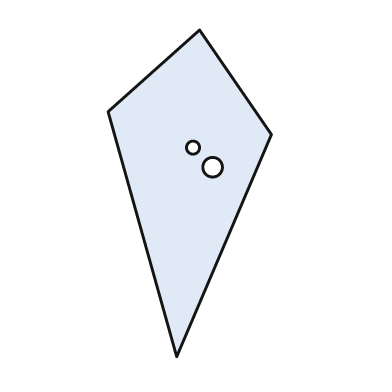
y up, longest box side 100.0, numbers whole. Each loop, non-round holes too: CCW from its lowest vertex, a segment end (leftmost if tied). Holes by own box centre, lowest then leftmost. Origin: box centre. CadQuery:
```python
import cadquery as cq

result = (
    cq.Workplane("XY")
    .moveTo(-4.0, -50.0)
    .lineTo(25.0, 18.0)
    .lineTo(3.0, 50.0)
    .lineTo(-25.0, 25.0)
    .close()
    .moveTo(7.0, 8.0)
    .circle(3.0)
    .moveTo(1.0, 14.0)
    .circle(2.0)
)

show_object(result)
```